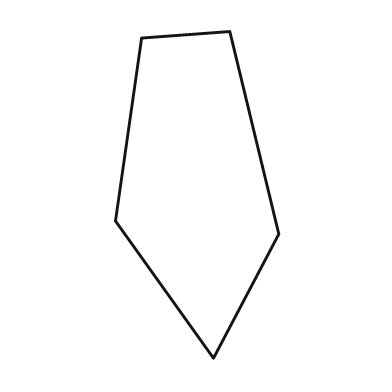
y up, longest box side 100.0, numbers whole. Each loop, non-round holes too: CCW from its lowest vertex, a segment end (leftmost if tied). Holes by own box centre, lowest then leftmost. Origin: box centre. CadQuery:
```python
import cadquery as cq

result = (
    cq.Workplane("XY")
    .moveTo(5.0, -50.0)
    .lineTo(25.0, -12.0)
    .lineTo(10.0, 50.0)
    .lineTo(-17.0, 48.0)
    .lineTo(-25.0, -8.0)
    .close()
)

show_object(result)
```